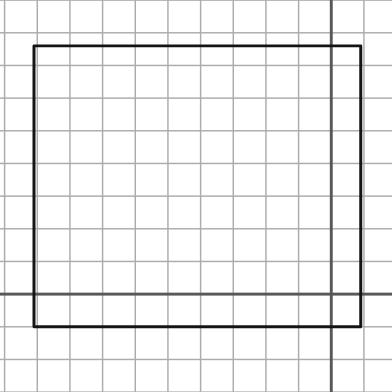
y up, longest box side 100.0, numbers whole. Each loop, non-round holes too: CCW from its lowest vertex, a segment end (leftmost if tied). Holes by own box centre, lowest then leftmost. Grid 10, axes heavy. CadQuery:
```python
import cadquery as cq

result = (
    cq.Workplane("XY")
    .moveTo(-91.0, -10.0)
    .lineTo(9.0, -10.0)
    .lineTo(9.0, 76.0)
    .lineTo(-91.0, 76.0)
    .close()
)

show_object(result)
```